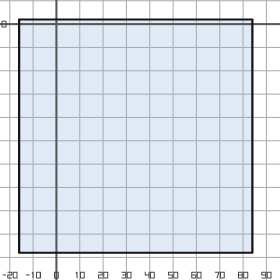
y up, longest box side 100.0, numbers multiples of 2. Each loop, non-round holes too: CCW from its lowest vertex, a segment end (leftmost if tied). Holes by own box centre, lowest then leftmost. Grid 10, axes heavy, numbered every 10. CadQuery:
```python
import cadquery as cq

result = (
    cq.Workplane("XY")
    .moveTo(-16.0, -98.0)
    .lineTo(84.0, -98.0)
    .lineTo(84.0, 2.0)
    .lineTo(-16.0, 2.0)
    .close()
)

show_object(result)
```